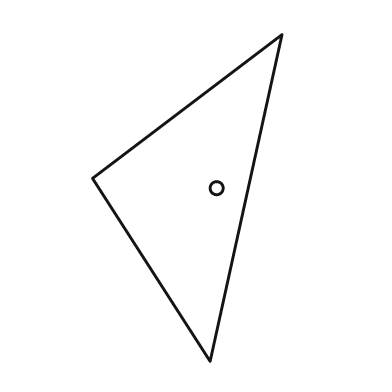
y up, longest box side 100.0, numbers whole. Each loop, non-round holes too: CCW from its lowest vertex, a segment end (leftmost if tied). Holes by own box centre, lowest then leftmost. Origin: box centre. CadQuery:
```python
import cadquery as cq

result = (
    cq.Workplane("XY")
    .moveTo(7.0, -50.0)
    .lineTo(29.0, 50.0)
    .lineTo(-29.0, 6.0)
    .close()
    .moveTo(9.0, 3.0)
    .circle(2.0)
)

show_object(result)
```